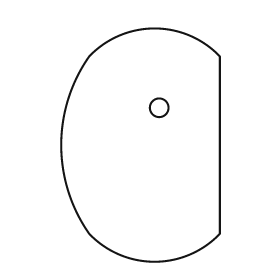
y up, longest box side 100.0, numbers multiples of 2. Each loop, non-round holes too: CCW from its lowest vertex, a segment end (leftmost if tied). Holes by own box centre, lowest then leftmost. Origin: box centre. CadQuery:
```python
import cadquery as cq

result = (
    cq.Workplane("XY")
    .moveTo(-22.0, -38.0)
    .threePointArc((6.0, -50.0), (34.0, -38.0))
    .lineTo(34.0, 38.0)
    .threePointArc((6.0, 50.0), (-22.0, 38.0))
    .threePointArc((-34.0, 0.0), (-22.0, -38.0))
    .close()
    .moveTo(8.0, 16.0)
    .circle(4.0)
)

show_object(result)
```